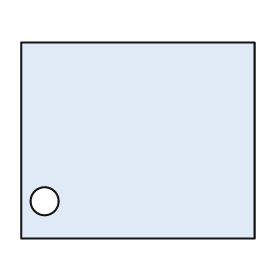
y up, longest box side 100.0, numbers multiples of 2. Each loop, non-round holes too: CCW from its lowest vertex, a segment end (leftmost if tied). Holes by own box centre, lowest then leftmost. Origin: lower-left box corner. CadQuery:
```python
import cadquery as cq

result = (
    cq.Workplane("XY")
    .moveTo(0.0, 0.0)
    .lineTo(100.0, 0.0)
    .lineTo(100.0, 84.0)
    .lineTo(0.0, 84.0)
    .close()
    .moveTo(10.0, 16.0)
    .circle(6.0)
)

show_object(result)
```